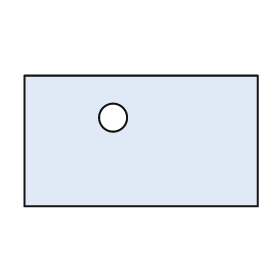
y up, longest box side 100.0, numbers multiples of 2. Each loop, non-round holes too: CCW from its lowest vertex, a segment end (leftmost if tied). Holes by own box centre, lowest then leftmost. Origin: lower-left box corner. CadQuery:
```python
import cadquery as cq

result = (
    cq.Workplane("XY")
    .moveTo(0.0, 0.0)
    .lineTo(100.0, 0.0)
    .lineTo(100.0, 56.0)
    .lineTo(0.0, 56.0)
    .close()
    .moveTo(38.0, 38.0)
    .circle(6.0)
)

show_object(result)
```